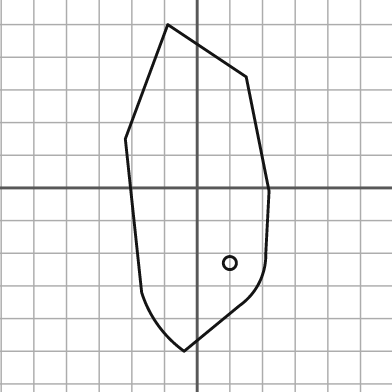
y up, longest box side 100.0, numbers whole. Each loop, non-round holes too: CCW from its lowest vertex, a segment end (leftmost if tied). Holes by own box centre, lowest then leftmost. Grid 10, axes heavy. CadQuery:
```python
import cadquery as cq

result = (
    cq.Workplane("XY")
    .moveTo(-4.0, -50.0)
    .lineTo(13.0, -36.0)
    .threePointArc((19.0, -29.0), (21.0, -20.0))
    .lineTo(22.0, -1.0)
    .lineTo(15.0, 34.0)
    .lineTo(-9.0, 50.0)
    .lineTo(-22.0, 15.0)
    .lineTo(-17.0, -32.0)
    .threePointArc((-12.0, -42.0), (-4.0, -50.0))
    .close()
    .moveTo(10.0, -23.0)
    .circle(2.0)
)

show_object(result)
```